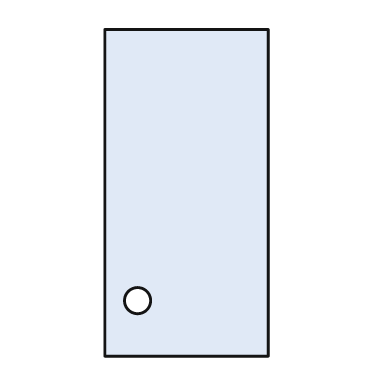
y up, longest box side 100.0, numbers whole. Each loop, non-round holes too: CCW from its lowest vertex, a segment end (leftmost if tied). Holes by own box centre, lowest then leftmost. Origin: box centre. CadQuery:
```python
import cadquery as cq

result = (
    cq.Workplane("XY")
    .moveTo(-25.0, -50.0)
    .lineTo(25.0, -50.0)
    .lineTo(25.0, 50.0)
    .lineTo(-25.0, 50.0)
    .close()
    .moveTo(-15.0, -33.0)
    .circle(4.0)
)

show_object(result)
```